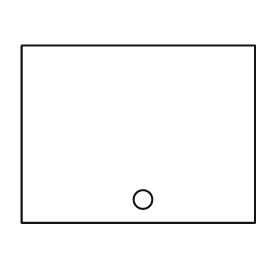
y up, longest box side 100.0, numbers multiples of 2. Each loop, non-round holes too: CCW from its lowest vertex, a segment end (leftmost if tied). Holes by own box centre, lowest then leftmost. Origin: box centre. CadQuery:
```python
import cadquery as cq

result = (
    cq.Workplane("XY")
    .moveTo(-50.0, -38.0)
    .lineTo(50.0, -38.0)
    .lineTo(50.0, 38.0)
    .lineTo(-50.0, 38.0)
    .close()
    .moveTo(2.0, -28.0)
    .circle(4.0)
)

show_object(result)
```